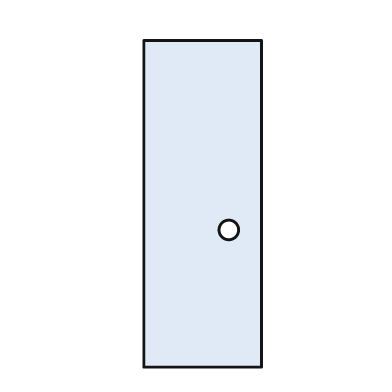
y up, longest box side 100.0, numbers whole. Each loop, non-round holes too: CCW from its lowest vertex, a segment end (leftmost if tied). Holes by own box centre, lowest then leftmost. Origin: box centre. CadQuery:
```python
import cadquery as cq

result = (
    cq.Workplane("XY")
    .moveTo(-18.0, -50.0)
    .lineTo(18.0, -50.0)
    .lineTo(18.0, 50.0)
    .lineTo(-18.0, 50.0)
    .close()
    .moveTo(8.0, -8.0)
    .circle(3.0)
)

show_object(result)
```